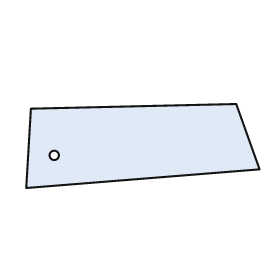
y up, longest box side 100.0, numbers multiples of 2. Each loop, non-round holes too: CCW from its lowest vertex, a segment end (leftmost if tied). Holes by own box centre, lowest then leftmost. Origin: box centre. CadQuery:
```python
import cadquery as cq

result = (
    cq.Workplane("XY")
    .moveTo(-50.0, -18.0)
    .lineTo(50.0, -10.0)
    .lineTo(40.0, 18.0)
    .lineTo(-48.0, 16.0)
    .close()
    .moveTo(-38.0, -4.0)
    .circle(2.0)
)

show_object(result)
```